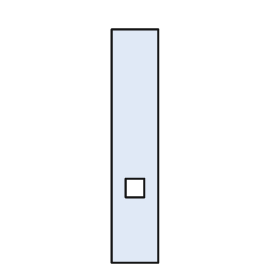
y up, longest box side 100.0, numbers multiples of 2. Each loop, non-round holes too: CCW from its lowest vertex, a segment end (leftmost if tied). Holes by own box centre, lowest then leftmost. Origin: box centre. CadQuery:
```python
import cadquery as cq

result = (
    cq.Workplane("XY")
    .moveTo(-10.0, -50.0)
    .lineTo(10.0, -50.0)
    .lineTo(10.0, 50.0)
    .lineTo(-10.0, 50.0)
    .close()
    .moveTo(-4.0, -22.0)
    .lineTo(4.0, -22.0)
    .lineTo(4.0, -14.0)
    .lineTo(-4.0, -14.0)
    .close()
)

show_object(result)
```